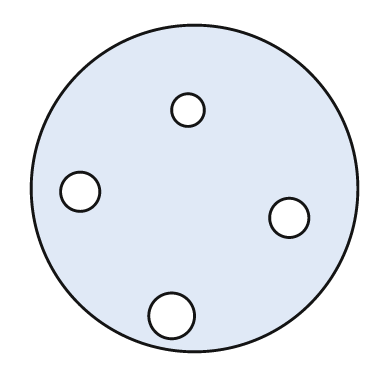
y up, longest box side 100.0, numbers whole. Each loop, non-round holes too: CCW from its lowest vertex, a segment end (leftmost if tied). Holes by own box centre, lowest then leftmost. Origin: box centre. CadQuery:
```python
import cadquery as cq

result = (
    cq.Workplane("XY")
    .moveTo(0.0, 0.0)
    .circle(50.0)
    .moveTo(-7.0, -39.0)
    .circle(7.0)
    .moveTo(29.0, -9.0)
    .circle(6.0)
    .moveTo(-35.0, -1.0)
    .circle(6.0)
    .moveTo(-2.0, 24.0)
    .circle(5.0)
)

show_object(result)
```